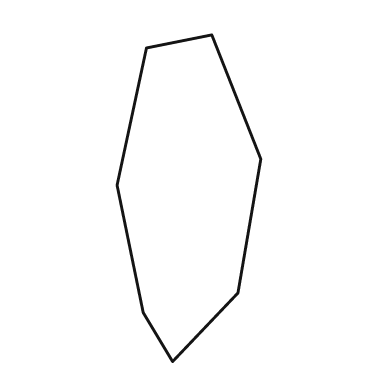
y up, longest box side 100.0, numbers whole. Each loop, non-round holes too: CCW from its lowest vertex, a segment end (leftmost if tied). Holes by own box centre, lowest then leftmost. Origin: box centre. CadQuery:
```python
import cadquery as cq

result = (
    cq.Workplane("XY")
    .moveTo(-5.0, -50.0)
    .lineTo(15.0, -29.0)
    .lineTo(22.0, 12.0)
    .lineTo(7.0, 50.0)
    .lineTo(-13.0, 46.0)
    .lineTo(-22.0, 4.0)
    .lineTo(-14.0, -35.0)
    .close()
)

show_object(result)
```